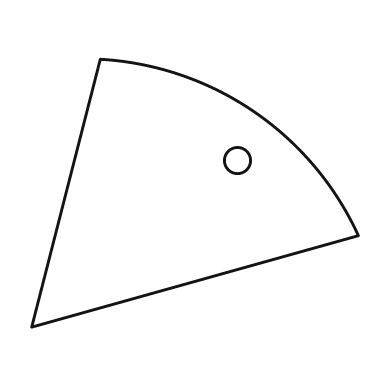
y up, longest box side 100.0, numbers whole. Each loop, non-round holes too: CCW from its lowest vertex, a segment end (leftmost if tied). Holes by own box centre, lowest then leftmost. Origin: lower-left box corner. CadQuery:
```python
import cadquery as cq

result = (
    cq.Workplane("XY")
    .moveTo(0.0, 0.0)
    .lineTo(100.0, 28.0)
    .threePointArc((68.0, 66.0), (21.0, 82.0))
    .close()
    .moveTo(63.0, 51.0)
    .circle(4.0)
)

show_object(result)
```